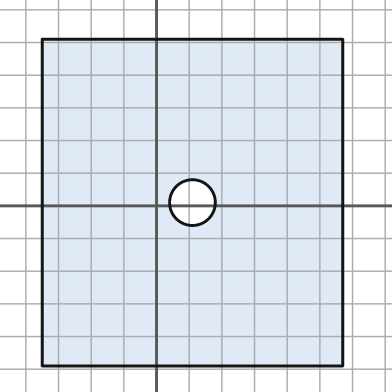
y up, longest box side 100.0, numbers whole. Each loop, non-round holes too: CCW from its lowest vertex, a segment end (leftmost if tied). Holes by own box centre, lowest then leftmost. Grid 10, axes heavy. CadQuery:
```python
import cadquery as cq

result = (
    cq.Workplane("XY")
    .moveTo(-35.0, -49.0)
    .lineTo(57.0, -49.0)
    .lineTo(57.0, 51.0)
    .lineTo(-35.0, 51.0)
    .close()
    .moveTo(11.0, 1.0)
    .circle(7.0)
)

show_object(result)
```